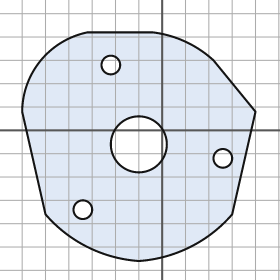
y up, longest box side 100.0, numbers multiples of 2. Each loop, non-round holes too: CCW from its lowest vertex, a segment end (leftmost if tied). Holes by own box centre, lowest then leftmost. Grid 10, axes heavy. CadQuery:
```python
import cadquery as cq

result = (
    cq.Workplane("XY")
    .moveTo(-10.0, -56.0)
    .threePointArc((12.0, -50.0), (30.0, -36.0))
    .lineTo(40.0, 8.0)
    .lineTo(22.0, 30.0)
    .threePointArc((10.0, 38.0), (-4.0, 42.0))
    .lineTo(-32.0, 42.0)
    .threePointArc((-52.0, 30.0), (-60.0, 8.0))
    .lineTo(-50.0, -36.0)
    .threePointArc((-32.0, -50.0), (-10.0, -56.0))
    .close()
    .moveTo(-34.0, -34.0)
    .circle(4.0)
    .moveTo(26.0, -12.0)
    .circle(4.0)
    .moveTo(-10.0, -6.0)
    .circle(12.0)
    .moveTo(-22.0, 28.0)
    .circle(4.0)
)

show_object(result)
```